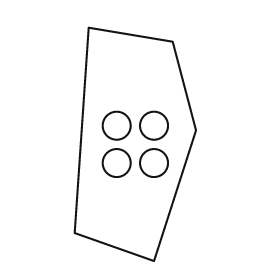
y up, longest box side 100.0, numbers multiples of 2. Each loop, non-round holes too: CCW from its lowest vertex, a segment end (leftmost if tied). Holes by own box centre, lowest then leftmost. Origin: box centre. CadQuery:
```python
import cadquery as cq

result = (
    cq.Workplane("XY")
    .moveTo(8.0, -50.0)
    .lineTo(26.0, 6.0)
    .lineTo(16.0, 44.0)
    .lineTo(-20.0, 50.0)
    .lineTo(-26.0, -38.0)
    .close()
    .moveTo(-8.0, -8.0)
    .circle(6.0)
    .moveTo(8.0, -8.0)
    .circle(6.0)
    .moveTo(-8.0, 8.0)
    .circle(6.0)
    .moveTo(8.0, 8.0)
    .circle(6.0)
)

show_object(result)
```